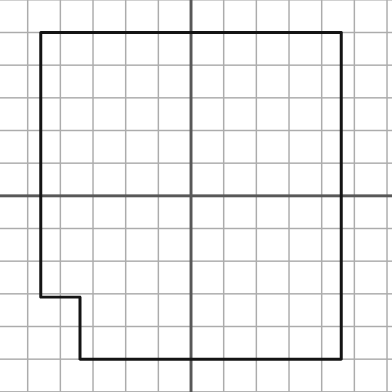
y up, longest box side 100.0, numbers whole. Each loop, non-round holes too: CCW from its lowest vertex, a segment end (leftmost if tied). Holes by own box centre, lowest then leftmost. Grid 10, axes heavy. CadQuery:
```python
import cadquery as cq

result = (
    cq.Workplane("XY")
    .moveTo(-34.0, -50.0)
    .lineTo(46.0, -50.0)
    .lineTo(46.0, 50.0)
    .lineTo(-46.0, 50.0)
    .lineTo(-46.0, -31.0)
    .lineTo(-34.0, -31.0)
    .close()
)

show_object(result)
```